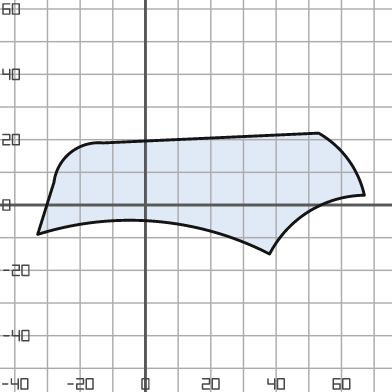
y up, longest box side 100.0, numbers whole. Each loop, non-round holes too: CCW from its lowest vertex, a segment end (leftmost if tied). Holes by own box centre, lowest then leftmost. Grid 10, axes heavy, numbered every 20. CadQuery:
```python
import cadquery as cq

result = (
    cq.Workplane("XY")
    .moveTo(38.0, -15.0)
    .threePointArc((50.0, -2.0), (67.0, 3.0))
    .threePointArc((62.0, 14.0), (53.0, 22.0))
    .lineTo(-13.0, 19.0)
    .threePointArc((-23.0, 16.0), (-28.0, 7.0))
    .lineTo(-33.0, -9.0)
    .threePointArc((3.0, -5.0), (38.0, -15.0))
    .close()
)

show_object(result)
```